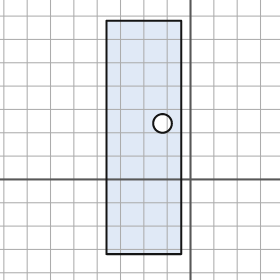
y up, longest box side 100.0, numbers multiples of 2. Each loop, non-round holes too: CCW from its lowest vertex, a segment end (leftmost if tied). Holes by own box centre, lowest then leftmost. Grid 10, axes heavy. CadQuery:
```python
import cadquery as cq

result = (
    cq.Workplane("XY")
    .moveTo(-36.0, -32.0)
    .lineTo(-4.0, -32.0)
    .lineTo(-4.0, 68.0)
    .lineTo(-36.0, 68.0)
    .close()
    .moveTo(-12.0, 24.0)
    .circle(4.0)
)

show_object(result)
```